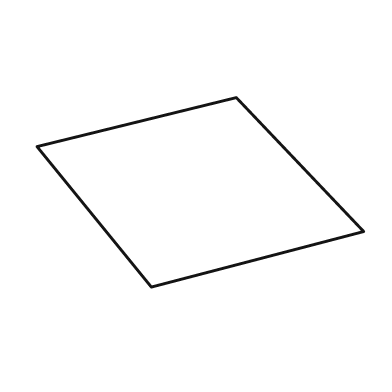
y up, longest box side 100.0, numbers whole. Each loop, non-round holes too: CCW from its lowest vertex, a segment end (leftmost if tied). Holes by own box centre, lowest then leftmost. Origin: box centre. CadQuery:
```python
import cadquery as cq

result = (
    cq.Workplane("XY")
    .moveTo(-15.0, -29.0)
    .lineTo(50.0, -12.0)
    .lineTo(11.0, 29.0)
    .lineTo(-50.0, 14.0)
    .close()
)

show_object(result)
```